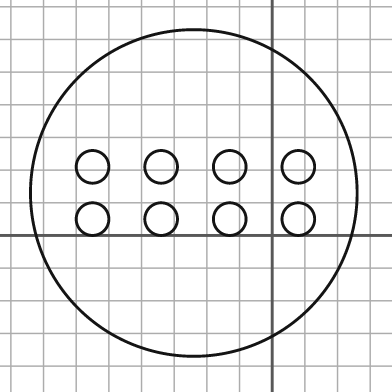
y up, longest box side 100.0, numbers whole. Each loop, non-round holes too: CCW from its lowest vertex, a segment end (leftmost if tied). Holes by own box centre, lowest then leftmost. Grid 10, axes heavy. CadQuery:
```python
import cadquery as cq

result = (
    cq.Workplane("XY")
    .moveTo(-24.0, 13.0)
    .circle(50.0)
    .moveTo(-55.0, 5.0)
    .circle(5.0)
    .moveTo(-34.0, 5.0)
    .circle(5.0)
    .moveTo(-13.0, 5.0)
    .circle(5.0)
    .moveTo(8.0, 5.0)
    .circle(5.0)
    .moveTo(-55.0, 21.0)
    .circle(5.0)
    .moveTo(-34.0, 21.0)
    .circle(5.0)
    .moveTo(-13.0, 21.0)
    .circle(5.0)
    .moveTo(8.0, 21.0)
    .circle(5.0)
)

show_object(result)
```